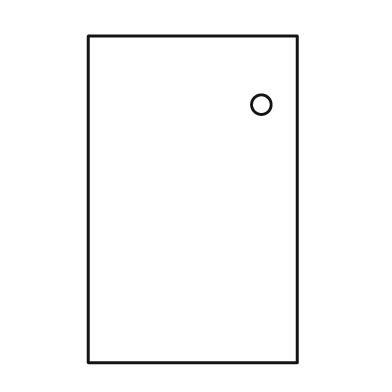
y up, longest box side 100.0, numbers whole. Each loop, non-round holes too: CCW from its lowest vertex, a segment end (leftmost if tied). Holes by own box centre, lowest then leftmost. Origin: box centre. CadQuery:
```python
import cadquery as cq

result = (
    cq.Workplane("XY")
    .moveTo(-32.0, -50.0)
    .lineTo(32.0, -50.0)
    .lineTo(32.0, 50.0)
    .lineTo(-32.0, 50.0)
    .close()
    .moveTo(21.0, 29.0)
    .circle(3.0)
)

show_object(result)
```